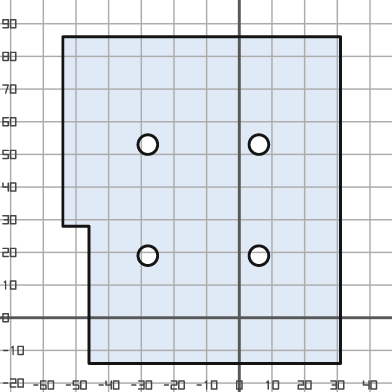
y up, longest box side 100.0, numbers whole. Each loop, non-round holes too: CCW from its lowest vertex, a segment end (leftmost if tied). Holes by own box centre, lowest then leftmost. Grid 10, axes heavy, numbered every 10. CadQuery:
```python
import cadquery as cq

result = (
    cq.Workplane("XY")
    .moveTo(-46.0, -14.0)
    .lineTo(31.0, -14.0)
    .lineTo(31.0, 86.0)
    .lineTo(-54.0, 86.0)
    .lineTo(-54.0, 28.0)
    .lineTo(-46.0, 28.0)
    .close()
    .moveTo(-28.0, 19.0)
    .circle(3.0)
    .moveTo(6.0, 19.0)
    .circle(3.0)
    .moveTo(-28.0, 53.0)
    .circle(3.0)
    .moveTo(6.0, 53.0)
    .circle(3.0)
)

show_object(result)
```